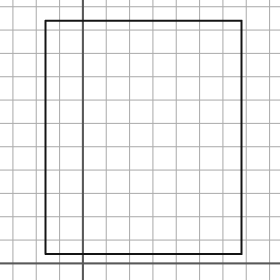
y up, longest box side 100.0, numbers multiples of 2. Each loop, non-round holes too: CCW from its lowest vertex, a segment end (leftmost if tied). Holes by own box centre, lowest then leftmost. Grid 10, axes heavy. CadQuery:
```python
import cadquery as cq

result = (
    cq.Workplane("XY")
    .moveTo(-16.0, 4.0)
    .lineTo(68.0, 4.0)
    .lineTo(68.0, 104.0)
    .lineTo(-16.0, 104.0)
    .close()
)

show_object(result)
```